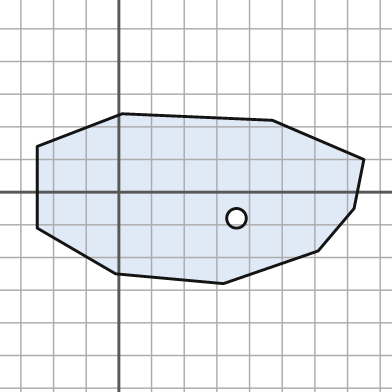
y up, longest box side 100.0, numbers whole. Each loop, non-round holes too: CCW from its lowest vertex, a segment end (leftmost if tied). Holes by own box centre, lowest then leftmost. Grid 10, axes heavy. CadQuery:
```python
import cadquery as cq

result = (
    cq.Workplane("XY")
    .moveTo(32.0, -28.0)
    .lineTo(61.0, -18.0)
    .lineTo(72.0, -5.0)
    .lineTo(75.0, 10.0)
    .lineTo(47.0, 22.0)
    .lineTo(1.0, 24.0)
    .lineTo(-25.0, 14.0)
    .lineTo(-25.0, -11.0)
    .lineTo(-1.0, -25.0)
    .close()
    .moveTo(36.0, -8.0)
    .circle(3.0)
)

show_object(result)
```